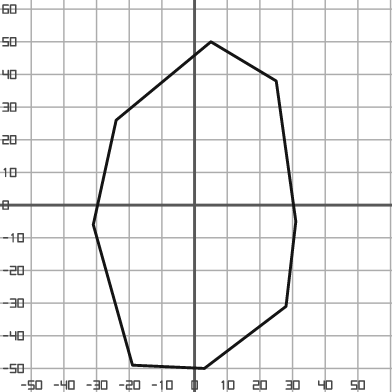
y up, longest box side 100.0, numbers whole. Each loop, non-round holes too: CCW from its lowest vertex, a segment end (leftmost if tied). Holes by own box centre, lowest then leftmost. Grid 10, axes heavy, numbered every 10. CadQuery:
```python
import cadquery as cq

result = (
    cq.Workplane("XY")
    .moveTo(3.0, -50.0)
    .lineTo(28.0, -31.0)
    .lineTo(31.0, -5.0)
    .lineTo(25.0, 38.0)
    .lineTo(5.0, 50.0)
    .lineTo(-24.0, 26.0)
    .lineTo(-31.0, -6.0)
    .lineTo(-19.0, -49.0)
    .close()
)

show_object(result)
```